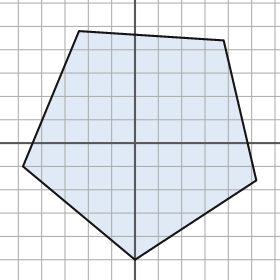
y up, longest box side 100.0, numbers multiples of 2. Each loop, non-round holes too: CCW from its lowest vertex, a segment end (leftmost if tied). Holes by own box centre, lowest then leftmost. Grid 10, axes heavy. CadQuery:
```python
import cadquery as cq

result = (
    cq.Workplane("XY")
    .moveTo(0.0, -50.0)
    .lineTo(52.0, -16.0)
    .lineTo(38.0, 44.0)
    .lineTo(-24.0, 48.0)
    .lineTo(-48.0, -10.0)
    .close()
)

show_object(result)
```